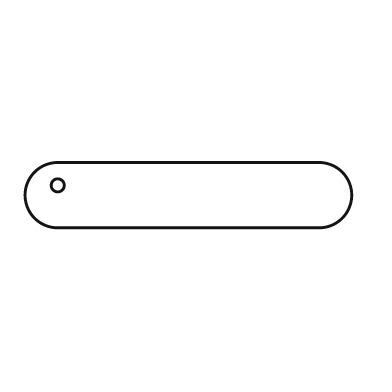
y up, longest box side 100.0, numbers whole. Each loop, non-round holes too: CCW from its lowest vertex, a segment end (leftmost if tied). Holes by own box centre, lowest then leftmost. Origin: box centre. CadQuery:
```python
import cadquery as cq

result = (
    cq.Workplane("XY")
    .moveTo(-40.0, -10.0)
    .lineTo(40.0, -10.0)
    .threePointArc((50.0, 0.0), (40.0, 10.0))
    .lineTo(-40.0, 10.0)
    .threePointArc((-50.0, 0.0), (-40.0, -10.0))
    .close()
    .moveTo(-40.0, 3.0)
    .circle(2.0)
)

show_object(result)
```